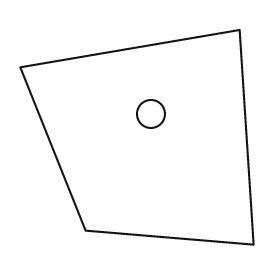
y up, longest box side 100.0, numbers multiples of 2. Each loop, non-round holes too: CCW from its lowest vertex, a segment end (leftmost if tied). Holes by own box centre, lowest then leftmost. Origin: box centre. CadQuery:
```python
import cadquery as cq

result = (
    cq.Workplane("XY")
    .moveTo(50.0, -46.0)
    .lineTo(44.0, 46.0)
    .lineTo(-50.0, 30.0)
    .lineTo(-22.0, -40.0)
    .close()
    .moveTo(6.0, 10.0)
    .circle(6.0)
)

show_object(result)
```